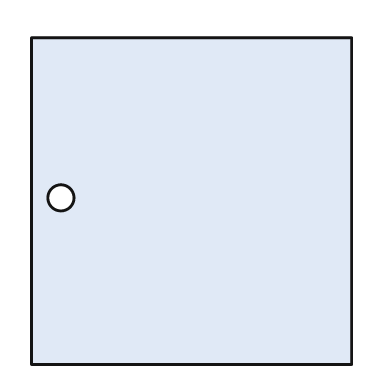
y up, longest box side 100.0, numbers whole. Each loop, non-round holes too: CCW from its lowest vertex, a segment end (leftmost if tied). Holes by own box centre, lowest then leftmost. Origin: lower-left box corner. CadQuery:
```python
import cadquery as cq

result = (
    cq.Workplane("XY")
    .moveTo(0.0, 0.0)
    .lineTo(98.0, 0.0)
    .lineTo(98.0, 100.0)
    .lineTo(0.0, 100.0)
    .close()
    .moveTo(9.0, 51.0)
    .circle(4.0)
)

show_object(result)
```